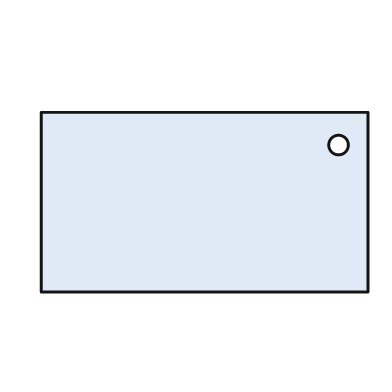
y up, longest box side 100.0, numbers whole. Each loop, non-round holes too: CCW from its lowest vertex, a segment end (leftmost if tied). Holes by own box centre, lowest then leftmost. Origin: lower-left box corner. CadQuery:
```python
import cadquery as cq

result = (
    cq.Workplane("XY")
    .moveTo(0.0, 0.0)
    .lineTo(100.0, 0.0)
    .lineTo(100.0, 55.0)
    .lineTo(0.0, 55.0)
    .close()
    .moveTo(91.0, 45.0)
    .circle(3.0)
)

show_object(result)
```